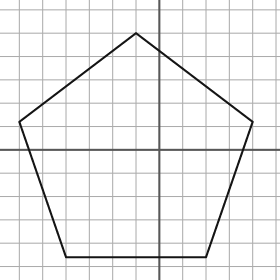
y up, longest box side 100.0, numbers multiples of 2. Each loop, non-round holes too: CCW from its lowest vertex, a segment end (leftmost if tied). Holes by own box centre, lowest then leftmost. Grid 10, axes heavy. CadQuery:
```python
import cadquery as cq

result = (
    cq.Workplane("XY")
    .moveTo(-40.0, -46.0)
    .lineTo(20.0, -46.0)
    .lineTo(40.0, 12.0)
    .lineTo(-10.0, 50.0)
    .lineTo(-60.0, 12.0)
    .close()
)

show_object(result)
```